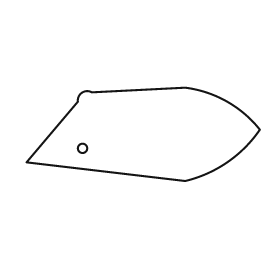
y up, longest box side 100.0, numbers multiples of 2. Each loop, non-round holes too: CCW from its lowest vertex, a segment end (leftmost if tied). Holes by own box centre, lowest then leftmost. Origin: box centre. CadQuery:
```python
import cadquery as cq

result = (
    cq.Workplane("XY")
    .moveTo(18.0, -20.0)
    .threePointArc((36.0, -12.0), (50.0, 2.0))
    .threePointArc((36.0, 14.0), (18.0, 20.0))
    .lineTo(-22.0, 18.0)
    .threePointArc((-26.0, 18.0), (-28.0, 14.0))
    .lineTo(-50.0, -12.0)
    .close()
    .moveTo(-26.0, -6.0)
    .circle(2.0)
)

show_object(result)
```